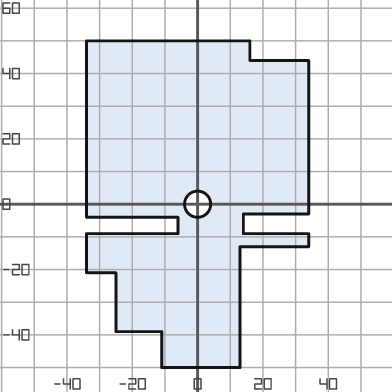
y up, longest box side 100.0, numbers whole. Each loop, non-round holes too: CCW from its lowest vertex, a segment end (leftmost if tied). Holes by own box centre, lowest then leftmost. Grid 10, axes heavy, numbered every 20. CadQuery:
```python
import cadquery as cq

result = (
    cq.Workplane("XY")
    .moveTo(-11.0, -50.0)
    .lineTo(13.0, -50.0)
    .lineTo(13.0, -13.0)
    .lineTo(34.0, -13.0)
    .lineTo(34.0, -9.0)
    .lineTo(14.0, -9.0)
    .lineTo(14.0, -3.0)
    .lineTo(34.0, -3.0)
    .lineTo(34.0, 44.0)
    .lineTo(16.0, 44.0)
    .lineTo(16.0, 50.0)
    .lineTo(-34.0, 50.0)
    .lineTo(-34.0, -4.0)
    .lineTo(-6.0, -4.0)
    .lineTo(-6.0, -9.0)
    .lineTo(-34.0, -9.0)
    .lineTo(-34.0, -21.0)
    .lineTo(-25.0, -21.0)
    .lineTo(-25.0, -39.0)
    .lineTo(-11.0, -39.0)
    .close()
    .moveTo(0.0, 0.0)
    .circle(4.0)
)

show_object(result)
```